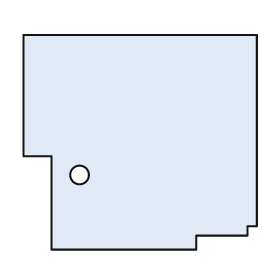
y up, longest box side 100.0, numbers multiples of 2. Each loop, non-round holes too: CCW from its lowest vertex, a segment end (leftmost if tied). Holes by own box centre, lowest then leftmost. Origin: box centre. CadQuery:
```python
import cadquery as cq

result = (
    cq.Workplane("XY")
    .moveTo(-38.0, -46.0)
    .lineTo(24.0, -46.0)
    .lineTo(24.0, -40.0)
    .lineTo(46.0, -40.0)
    .lineTo(46.0, -36.0)
    .lineTo(50.0, -36.0)
    .lineTo(50.0, 46.0)
    .lineTo(-50.0, 46.0)
    .lineTo(-50.0, -6.0)
    .lineTo(-38.0, -6.0)
    .close()
    .moveTo(-26.0, -14.0)
    .circle(4.0)
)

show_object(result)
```